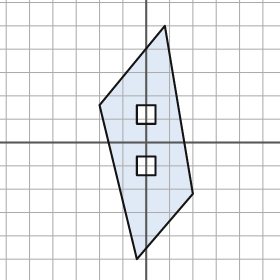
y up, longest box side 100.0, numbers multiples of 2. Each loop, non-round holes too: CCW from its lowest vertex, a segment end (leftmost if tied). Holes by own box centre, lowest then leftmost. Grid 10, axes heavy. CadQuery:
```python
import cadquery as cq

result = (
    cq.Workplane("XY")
    .moveTo(-4.0, -50.0)
    .lineTo(20.0, -22.0)
    .lineTo(8.0, 50.0)
    .lineTo(-20.0, 16.0)
    .close()
    .moveTo(-4.0, -14.0)
    .lineTo(4.0, -14.0)
    .lineTo(4.0, -6.0)
    .lineTo(-4.0, -6.0)
    .close()
    .moveTo(-4.0, 8.0)
    .lineTo(4.0, 8.0)
    .lineTo(4.0, 16.0)
    .lineTo(-4.0, 16.0)
    .close()
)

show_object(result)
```